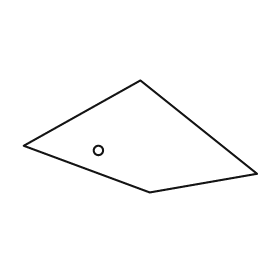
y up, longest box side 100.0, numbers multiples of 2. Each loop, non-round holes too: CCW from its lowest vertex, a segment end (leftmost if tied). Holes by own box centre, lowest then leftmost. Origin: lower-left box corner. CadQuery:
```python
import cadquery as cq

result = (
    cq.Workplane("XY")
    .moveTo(54.0, 0.0)
    .lineTo(100.0, 8.0)
    .lineTo(50.0, 48.0)
    .lineTo(0.0, 20.0)
    .close()
    .moveTo(32.0, 18.0)
    .circle(2.0)
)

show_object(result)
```